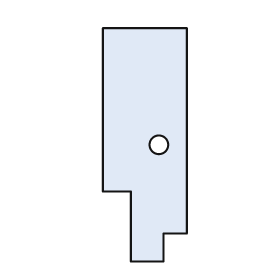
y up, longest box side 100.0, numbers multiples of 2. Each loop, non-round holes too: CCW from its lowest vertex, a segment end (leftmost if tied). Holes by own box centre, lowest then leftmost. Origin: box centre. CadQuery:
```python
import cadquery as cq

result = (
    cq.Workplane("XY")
    .moveTo(-6.0, -50.0)
    .lineTo(8.0, -50.0)
    .lineTo(8.0, -38.0)
    .lineTo(18.0, -38.0)
    .lineTo(18.0, 50.0)
    .lineTo(-18.0, 50.0)
    .lineTo(-18.0, -20.0)
    .lineTo(-6.0, -20.0)
    .close()
    .moveTo(6.0, 0.0)
    .circle(4.0)
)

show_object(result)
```